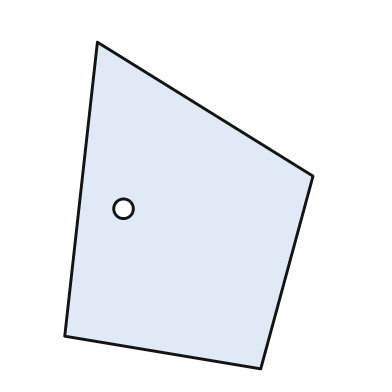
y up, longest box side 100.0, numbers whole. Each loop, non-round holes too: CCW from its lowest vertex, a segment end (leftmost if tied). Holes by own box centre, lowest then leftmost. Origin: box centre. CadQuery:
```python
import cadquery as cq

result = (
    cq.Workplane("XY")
    .moveTo(22.0, -50.0)
    .lineTo(38.0, 9.0)
    .lineTo(-28.0, 50.0)
    .lineTo(-38.0, -40.0)
    .close()
    .moveTo(-20.0, -1.0)
    .circle(3.0)
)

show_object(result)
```